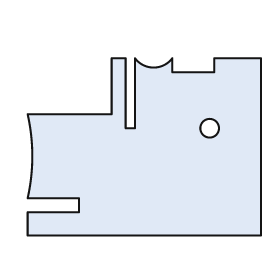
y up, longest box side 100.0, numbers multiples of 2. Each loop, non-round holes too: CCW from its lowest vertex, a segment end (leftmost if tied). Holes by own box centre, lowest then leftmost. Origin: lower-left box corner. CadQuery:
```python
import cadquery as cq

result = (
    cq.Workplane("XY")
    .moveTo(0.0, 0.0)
    .lineTo(100.0, 0.0)
    .lineTo(100.0, 76.0)
    .lineTo(80.0, 76.0)
    .lineTo(80.0, 70.0)
    .lineTo(62.0, 70.0)
    .lineTo(62.0, 76.0)
    .threePointArc((54.0, 72.0), (46.0, 76.0))
    .lineTo(46.0, 46.0)
    .lineTo(42.0, 46.0)
    .lineTo(42.0, 76.0)
    .lineTo(36.0, 76.0)
    .lineTo(36.0, 52.0)
    .lineTo(0.0, 52.0)
    .threePointArc((2.0, 34.0), (0.0, 16.0))
    .lineTo(22.0, 16.0)
    .lineTo(22.0, 10.0)
    .lineTo(0.0, 10.0)
    .close()
    .moveTo(78.0, 46.0)
    .circle(4.0)
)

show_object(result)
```